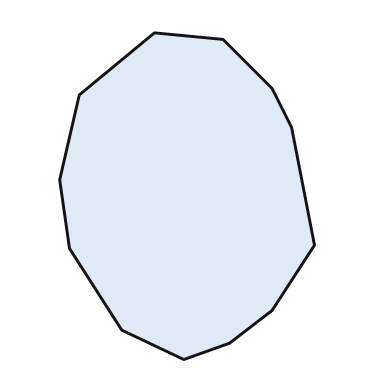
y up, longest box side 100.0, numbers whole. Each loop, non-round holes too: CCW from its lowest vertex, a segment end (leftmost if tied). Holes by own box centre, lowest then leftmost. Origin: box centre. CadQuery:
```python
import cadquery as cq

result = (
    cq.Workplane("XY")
    .moveTo(-1.0, -50.0)
    .lineTo(13.0, -45.0)
    .lineTo(26.0, -35.0)
    .lineTo(39.0, -15.0)
    .lineTo(32.0, 21.0)
    .lineTo(26.0, 33.0)
    .lineTo(11.0, 48.0)
    .lineTo(-10.0, 50.0)
    .lineTo(-33.0, 31.0)
    .lineTo(-39.0, 5.0)
    .lineTo(-36.0, -16.0)
    .lineTo(-20.0, -41.0)
    .close()
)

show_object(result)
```